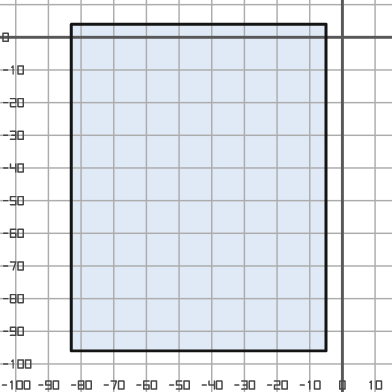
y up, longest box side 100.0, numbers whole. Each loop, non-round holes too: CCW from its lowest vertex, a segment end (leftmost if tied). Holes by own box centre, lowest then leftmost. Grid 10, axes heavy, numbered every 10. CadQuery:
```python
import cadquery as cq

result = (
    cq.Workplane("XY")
    .moveTo(-83.0, -96.0)
    .lineTo(-5.0, -96.0)
    .lineTo(-5.0, 4.0)
    .lineTo(-83.0, 4.0)
    .close()
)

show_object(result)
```